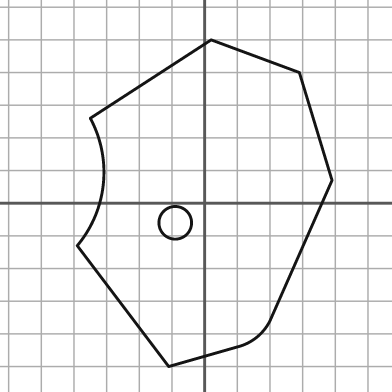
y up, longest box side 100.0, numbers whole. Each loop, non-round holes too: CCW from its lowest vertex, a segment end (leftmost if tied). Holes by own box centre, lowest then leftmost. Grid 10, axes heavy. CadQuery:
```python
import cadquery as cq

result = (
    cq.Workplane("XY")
    .moveTo(-11.0, -50.0)
    .lineTo(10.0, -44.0)
    .threePointArc((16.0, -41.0), (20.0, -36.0))
    .lineTo(39.0, 7.0)
    .lineTo(29.0, 40.0)
    .lineTo(2.0, 50.0)
    .lineTo(-35.0, 26.0)
    .threePointArc((-31.0, 6.0), (-39.0, -13.0))
    .close()
    .moveTo(-9.0, -6.0)
    .circle(5.0)
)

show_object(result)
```